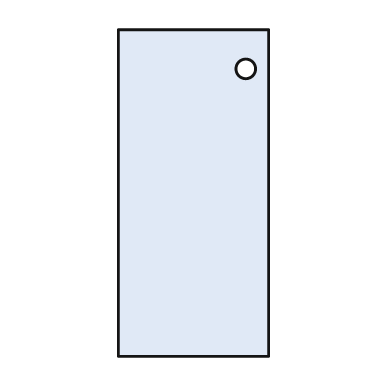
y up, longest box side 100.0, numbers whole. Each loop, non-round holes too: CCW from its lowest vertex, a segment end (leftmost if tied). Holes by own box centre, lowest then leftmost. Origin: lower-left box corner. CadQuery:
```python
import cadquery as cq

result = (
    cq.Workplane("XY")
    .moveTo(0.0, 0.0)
    .lineTo(46.0, 0.0)
    .lineTo(46.0, 100.0)
    .lineTo(0.0, 100.0)
    .close()
    .moveTo(39.0, 88.0)
    .circle(3.0)
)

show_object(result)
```